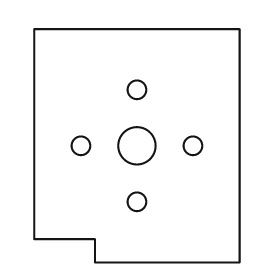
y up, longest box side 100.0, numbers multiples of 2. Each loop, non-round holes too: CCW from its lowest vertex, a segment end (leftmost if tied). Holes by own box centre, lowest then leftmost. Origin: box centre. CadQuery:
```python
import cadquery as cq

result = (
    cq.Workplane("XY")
    .moveTo(-18.0, -50.0)
    .lineTo(44.0, -50.0)
    .lineTo(44.0, 50.0)
    .lineTo(-44.0, 50.0)
    .lineTo(-44.0, -40.0)
    .lineTo(-18.0, -40.0)
    .close()
    .moveTo(0.0, -24.0)
    .circle(4.0)
    .moveTo(-24.0, 0.0)
    .circle(4.0)
    .moveTo(0.0, 0.0)
    .circle(8.0)
    .moveTo(24.0, 0.0)
    .circle(4.0)
    .moveTo(0.0, 24.0)
    .circle(4.0)
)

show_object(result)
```